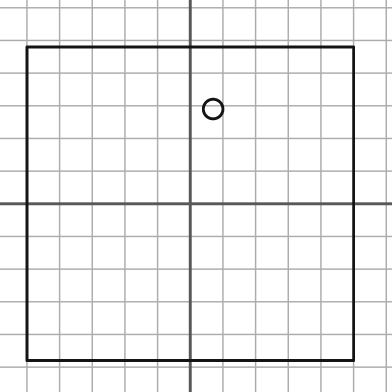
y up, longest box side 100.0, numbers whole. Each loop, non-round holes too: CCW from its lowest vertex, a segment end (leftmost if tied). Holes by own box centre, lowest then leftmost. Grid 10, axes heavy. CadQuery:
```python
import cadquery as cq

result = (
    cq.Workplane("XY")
    .moveTo(-50.0, -48.0)
    .lineTo(50.0, -48.0)
    .lineTo(50.0, 48.0)
    .lineTo(-50.0, 48.0)
    .close()
    .moveTo(7.0, 29.0)
    .circle(3.0)
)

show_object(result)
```